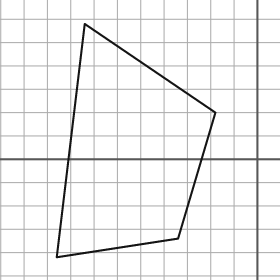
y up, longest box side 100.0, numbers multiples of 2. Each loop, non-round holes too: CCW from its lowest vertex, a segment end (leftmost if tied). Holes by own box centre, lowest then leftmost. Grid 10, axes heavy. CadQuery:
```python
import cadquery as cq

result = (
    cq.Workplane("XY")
    .moveTo(-86.0, -42.0)
    .lineTo(-34.0, -34.0)
    .lineTo(-18.0, 20.0)
    .lineTo(-74.0, 58.0)
    .close()
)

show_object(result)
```